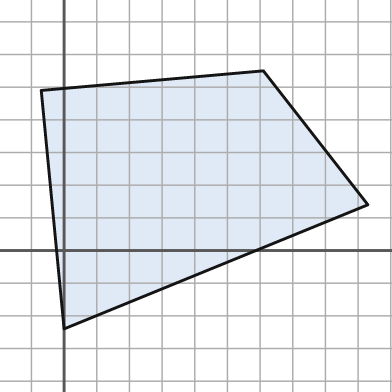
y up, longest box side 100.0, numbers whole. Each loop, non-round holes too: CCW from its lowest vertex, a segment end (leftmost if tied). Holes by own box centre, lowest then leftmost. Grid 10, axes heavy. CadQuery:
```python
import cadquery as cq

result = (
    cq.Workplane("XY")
    .moveTo(0.0, -24.0)
    .lineTo(93.0, 14.0)
    .lineTo(61.0, 55.0)
    .lineTo(-7.0, 49.0)
    .close()
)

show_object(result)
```